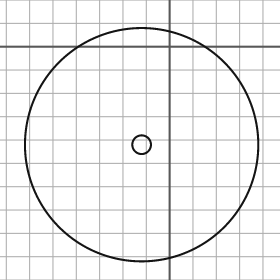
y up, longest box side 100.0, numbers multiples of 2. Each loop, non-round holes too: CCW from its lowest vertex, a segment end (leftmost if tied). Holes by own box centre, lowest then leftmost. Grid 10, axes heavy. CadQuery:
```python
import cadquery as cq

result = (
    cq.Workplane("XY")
    .moveTo(-12.0, -42.0)
    .circle(50.0)
    .moveTo(-12.0, -42.0)
    .circle(4.0)
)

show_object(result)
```